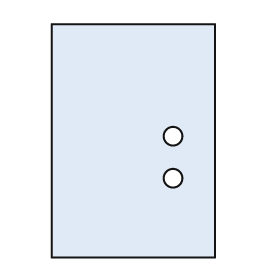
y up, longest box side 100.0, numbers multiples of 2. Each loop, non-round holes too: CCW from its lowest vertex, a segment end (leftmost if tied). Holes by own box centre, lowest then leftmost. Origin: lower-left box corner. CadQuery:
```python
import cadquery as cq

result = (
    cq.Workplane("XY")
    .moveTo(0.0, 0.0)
    .lineTo(70.0, 0.0)
    .lineTo(70.0, 100.0)
    .lineTo(0.0, 100.0)
    .close()
    .moveTo(52.0, 34.0)
    .circle(4.0)
    .moveTo(52.0, 52.0)
    .circle(4.0)
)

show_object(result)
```